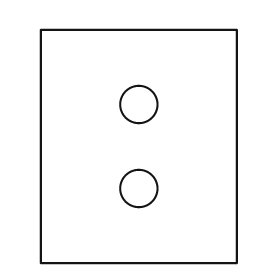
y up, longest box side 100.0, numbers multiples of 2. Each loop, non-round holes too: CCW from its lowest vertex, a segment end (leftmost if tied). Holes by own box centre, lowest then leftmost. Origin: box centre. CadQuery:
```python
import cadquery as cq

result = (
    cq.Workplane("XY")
    .moveTo(-42.0, -50.0)
    .lineTo(42.0, -50.0)
    .lineTo(42.0, 50.0)
    .lineTo(-42.0, 50.0)
    .close()
    .moveTo(0.0, -18.0)
    .circle(8.0)
    .moveTo(0.0, 18.0)
    .circle(8.0)
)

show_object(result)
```